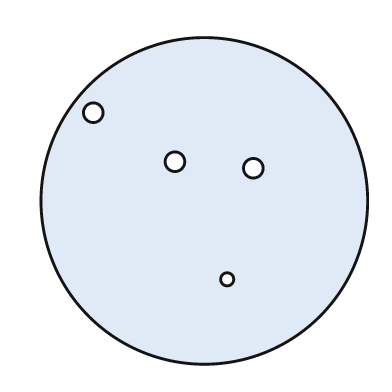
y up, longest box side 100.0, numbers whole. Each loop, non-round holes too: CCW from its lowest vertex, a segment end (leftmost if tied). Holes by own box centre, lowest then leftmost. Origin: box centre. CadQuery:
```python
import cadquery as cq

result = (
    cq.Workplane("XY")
    .moveTo(0.0, 0.0)
    .circle(50.0)
    .moveTo(7.0, -24.0)
    .circle(2.0)
    .moveTo(15.0, 10.0)
    .circle(3.0)
    .moveTo(-9.0, 12.0)
    .circle(3.0)
    .moveTo(-34.0, 27.0)
    .circle(3.0)
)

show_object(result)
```